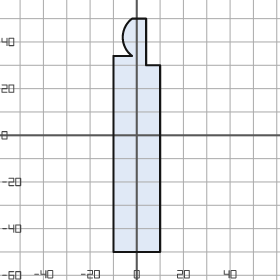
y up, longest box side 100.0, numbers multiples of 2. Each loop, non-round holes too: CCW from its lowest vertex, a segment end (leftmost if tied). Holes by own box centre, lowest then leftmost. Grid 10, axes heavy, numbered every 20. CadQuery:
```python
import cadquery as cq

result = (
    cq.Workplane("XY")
    .moveTo(-10.0, -50.0)
    .lineTo(10.0, -50.0)
    .lineTo(10.0, 30.0)
    .lineTo(4.0, 30.0)
    .lineTo(4.0, 50.0)
    .lineTo(-2.0, 50.0)
    .threePointArc((-6.0, 42.0), (-2.0, 34.0))
    .lineTo(-10.0, 34.0)
    .close()
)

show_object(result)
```